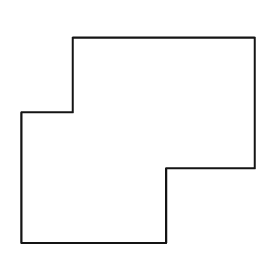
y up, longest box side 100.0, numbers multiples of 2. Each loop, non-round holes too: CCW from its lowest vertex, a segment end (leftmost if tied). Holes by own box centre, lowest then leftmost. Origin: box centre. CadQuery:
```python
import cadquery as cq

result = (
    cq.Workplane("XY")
    .moveTo(-50.0, -44.0)
    .lineTo(12.0, -44.0)
    .lineTo(12.0, -12.0)
    .lineTo(50.0, -12.0)
    .lineTo(50.0, 44.0)
    .lineTo(-28.0, 44.0)
    .lineTo(-28.0, 12.0)
    .lineTo(-50.0, 12.0)
    .close()
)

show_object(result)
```